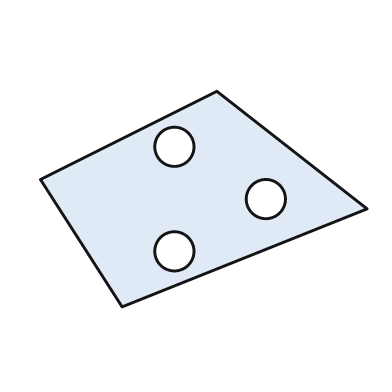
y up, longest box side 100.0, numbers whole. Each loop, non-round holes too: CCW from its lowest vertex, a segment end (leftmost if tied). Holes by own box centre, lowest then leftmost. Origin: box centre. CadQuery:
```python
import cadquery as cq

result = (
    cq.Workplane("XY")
    .moveTo(-25.0, -33.0)
    .lineTo(50.0, -3.0)
    .lineTo(4.0, 33.0)
    .lineTo(-50.0, 6.0)
    .close()
    .moveTo(-9.0, -16.0)
    .circle(6.0)
    .moveTo(19.0, 0.0)
    .circle(6.0)
    .moveTo(-9.0, 16.0)
    .circle(6.0)
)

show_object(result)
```